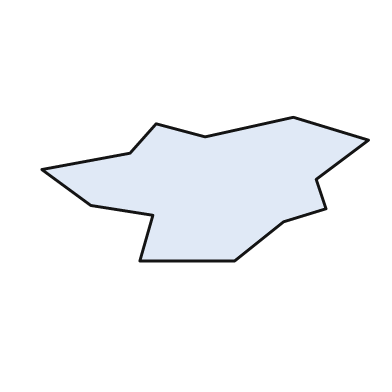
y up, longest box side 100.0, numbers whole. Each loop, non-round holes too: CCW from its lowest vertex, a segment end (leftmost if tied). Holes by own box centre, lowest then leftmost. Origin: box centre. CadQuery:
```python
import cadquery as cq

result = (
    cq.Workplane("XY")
    .moveTo(-20.0, -22.0)
    .lineTo(9.0, -22.0)
    .lineTo(24.0, -10.0)
    .lineTo(37.0, -6.0)
    .lineTo(34.0, 3.0)
    .lineTo(50.0, 15.0)
    .lineTo(27.0, 22.0)
    .lineTo(0.0, 16.0)
    .lineTo(-15.0, 20.0)
    .lineTo(-23.0, 11.0)
    .lineTo(-50.0, 6.0)
    .lineTo(-35.0, -5.0)
    .lineTo(-16.0, -8.0)
    .close()
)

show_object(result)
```